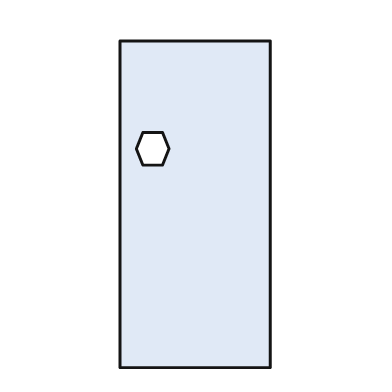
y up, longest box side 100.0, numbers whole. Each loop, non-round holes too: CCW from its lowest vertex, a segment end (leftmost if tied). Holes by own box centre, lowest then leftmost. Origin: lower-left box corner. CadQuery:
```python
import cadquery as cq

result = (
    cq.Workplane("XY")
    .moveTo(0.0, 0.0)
    .lineTo(46.0, 0.0)
    .lineTo(46.0, 100.0)
    .lineTo(0.0, 100.0)
    .close()
    .moveTo(7.0, 62.0)
    .lineTo(13.0, 62.0)
    .lineTo(15.0, 67.0)
    .lineTo(13.0, 72.0)
    .lineTo(7.0, 72.0)
    .lineTo(5.0, 67.0)
    .close()
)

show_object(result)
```